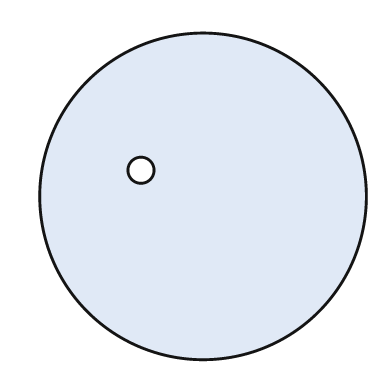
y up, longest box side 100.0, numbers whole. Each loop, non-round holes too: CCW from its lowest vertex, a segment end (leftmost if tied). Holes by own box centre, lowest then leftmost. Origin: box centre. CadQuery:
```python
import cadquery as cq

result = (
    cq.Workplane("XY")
    .moveTo(0.0, 0.0)
    .circle(50.0)
    .moveTo(-19.0, 8.0)
    .circle(4.0)
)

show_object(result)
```